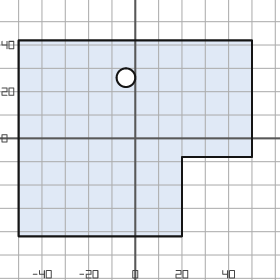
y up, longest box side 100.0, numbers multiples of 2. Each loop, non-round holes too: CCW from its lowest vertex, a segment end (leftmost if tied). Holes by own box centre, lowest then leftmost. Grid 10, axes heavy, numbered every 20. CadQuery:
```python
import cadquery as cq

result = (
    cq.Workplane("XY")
    .moveTo(-50.0, -42.0)
    .lineTo(20.0, -42.0)
    .lineTo(20.0, -8.0)
    .lineTo(50.0, -8.0)
    .lineTo(50.0, 42.0)
    .lineTo(-50.0, 42.0)
    .close()
    .moveTo(-4.0, 26.0)
    .circle(4.0)
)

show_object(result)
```